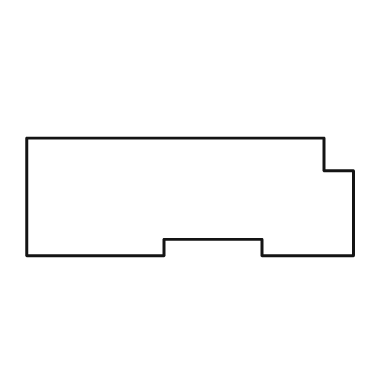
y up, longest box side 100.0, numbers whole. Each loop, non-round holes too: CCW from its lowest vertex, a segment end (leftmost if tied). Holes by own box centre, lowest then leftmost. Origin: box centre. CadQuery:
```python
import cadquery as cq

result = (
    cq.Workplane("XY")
    .moveTo(-50.0, -18.0)
    .lineTo(-8.0, -18.0)
    .lineTo(-8.0, -13.0)
    .lineTo(22.0, -13.0)
    .lineTo(22.0, -18.0)
    .lineTo(50.0, -18.0)
    .lineTo(50.0, 8.0)
    .lineTo(41.0, 8.0)
    .lineTo(41.0, 18.0)
    .lineTo(-50.0, 18.0)
    .close()
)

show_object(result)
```